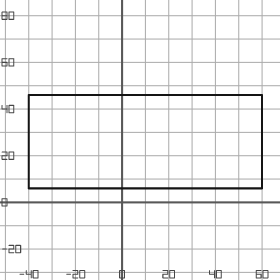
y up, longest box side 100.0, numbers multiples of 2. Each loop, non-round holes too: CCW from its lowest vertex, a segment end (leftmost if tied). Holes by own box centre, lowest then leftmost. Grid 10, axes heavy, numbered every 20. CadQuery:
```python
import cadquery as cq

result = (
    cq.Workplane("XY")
    .moveTo(-40.0, 6.0)
    .lineTo(60.0, 6.0)
    .lineTo(60.0, 46.0)
    .lineTo(-40.0, 46.0)
    .close()
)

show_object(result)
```